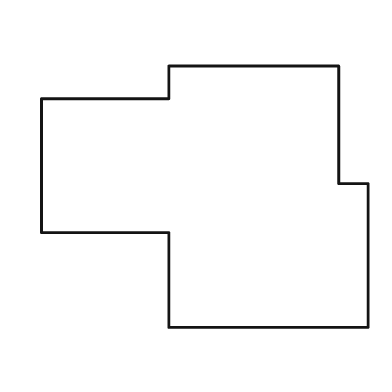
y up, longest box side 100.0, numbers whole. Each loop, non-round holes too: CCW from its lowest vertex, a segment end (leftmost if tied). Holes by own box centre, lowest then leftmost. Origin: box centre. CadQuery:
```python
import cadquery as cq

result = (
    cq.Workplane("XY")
    .moveTo(-11.0, -40.0)
    .lineTo(50.0, -40.0)
    .lineTo(50.0, 4.0)
    .lineTo(41.0, 4.0)
    .lineTo(41.0, 40.0)
    .lineTo(-11.0, 40.0)
    .lineTo(-11.0, 30.0)
    .lineTo(-50.0, 30.0)
    .lineTo(-50.0, -11.0)
    .lineTo(-11.0, -11.0)
    .close()
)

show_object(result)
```